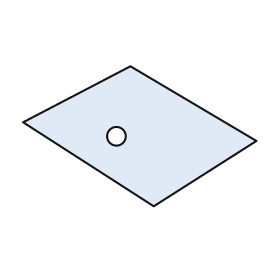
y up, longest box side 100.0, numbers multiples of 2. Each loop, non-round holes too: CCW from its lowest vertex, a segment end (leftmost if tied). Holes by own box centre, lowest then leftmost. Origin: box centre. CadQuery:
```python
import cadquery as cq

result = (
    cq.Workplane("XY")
    .moveTo(6.0, -30.0)
    .lineTo(50.0, -2.0)
    .lineTo(-4.0, 30.0)
    .lineTo(-50.0, 6.0)
    .close()
    .moveTo(-10.0, 0.0)
    .circle(4.0)
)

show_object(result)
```